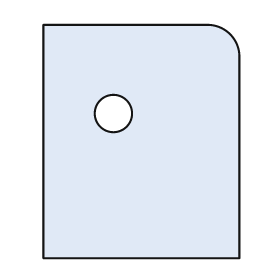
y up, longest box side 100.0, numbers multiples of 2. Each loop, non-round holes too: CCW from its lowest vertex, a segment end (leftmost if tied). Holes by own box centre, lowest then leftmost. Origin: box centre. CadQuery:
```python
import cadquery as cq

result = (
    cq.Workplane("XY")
    .moveTo(-42.0, -50.0)
    .lineTo(42.0, -50.0)
    .lineTo(42.0, 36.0)
    .threePointArc((38.0, 46.0), (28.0, 50.0))
    .lineTo(-42.0, 50.0)
    .close()
    .moveTo(-12.0, 12.0)
    .circle(8.0)
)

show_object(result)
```